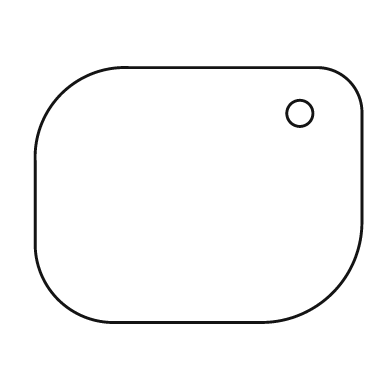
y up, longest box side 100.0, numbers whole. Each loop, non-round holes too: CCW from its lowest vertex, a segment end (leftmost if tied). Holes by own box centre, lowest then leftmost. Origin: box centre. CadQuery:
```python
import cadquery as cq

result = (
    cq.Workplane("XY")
    .moveTo(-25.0, -39.0)
    .lineTo(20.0, -39.0)
    .threePointArc((41.0, -30.0), (50.0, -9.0))
    .lineTo(50.0, 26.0)
    .threePointArc((46.0, 35.0), (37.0, 39.0))
    .lineTo(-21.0, 39.0)
    .threePointArc((-42.0, 31.0), (-50.0, 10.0))
    .lineTo(-50.0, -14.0)
    .threePointArc((-43.0, -32.0), (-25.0, -39.0))
    .close()
    .moveTo(31.0, 25.0)
    .circle(4.0)
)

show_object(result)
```